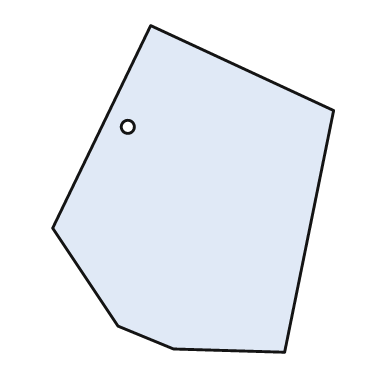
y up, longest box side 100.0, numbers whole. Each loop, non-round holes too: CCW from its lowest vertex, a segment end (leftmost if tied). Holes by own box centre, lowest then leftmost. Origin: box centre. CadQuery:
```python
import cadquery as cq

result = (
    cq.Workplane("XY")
    .moveTo(28.0, -50.0)
    .lineTo(43.0, 24.0)
    .lineTo(-13.0, 50.0)
    .lineTo(-43.0, -12.0)
    .lineTo(-23.0, -42.0)
    .lineTo(-6.0, -49.0)
    .close()
    .moveTo(-20.0, 19.0)
    .circle(2.0)
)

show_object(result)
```